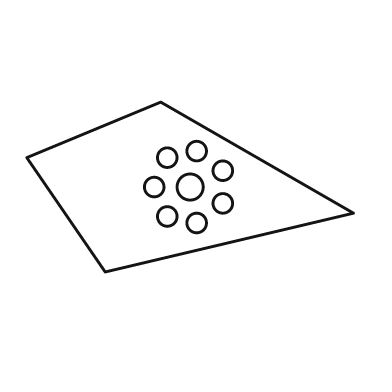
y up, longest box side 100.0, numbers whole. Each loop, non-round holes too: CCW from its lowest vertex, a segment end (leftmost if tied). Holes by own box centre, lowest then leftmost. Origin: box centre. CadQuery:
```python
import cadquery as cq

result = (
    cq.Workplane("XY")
    .moveTo(-26.0, -26.0)
    .lineTo(50.0, -8.0)
    .lineTo(-9.0, 26.0)
    .lineTo(-50.0, 9.0)
    .close()
    .moveTo(2.0, -11.0)
    .circle(3.0)
    .moveTo(-7.0, -9.0)
    .circle(3.0)
    .moveTo(10.0, -5.0)
    .circle(3.0)
    .moveTo(-11.0, 0.0)
    .circle(3.0)
    .moveTo(0.0, 0.0)
    .circle(4.0)
    .moveTo(10.0, 5.0)
    .circle(3.0)
    .moveTo(-7.0, 9.0)
    .circle(3.0)
    .moveTo(2.0, 11.0)
    .circle(3.0)
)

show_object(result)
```